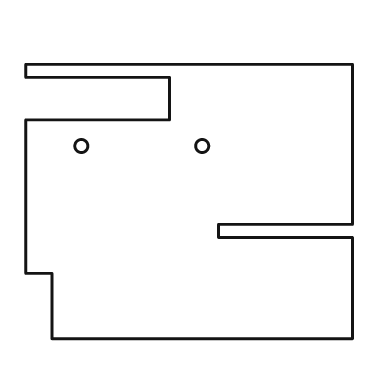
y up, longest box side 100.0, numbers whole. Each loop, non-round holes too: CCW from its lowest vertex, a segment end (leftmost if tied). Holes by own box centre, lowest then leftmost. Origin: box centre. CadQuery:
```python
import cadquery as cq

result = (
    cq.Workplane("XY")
    .moveTo(-42.0, -42.0)
    .lineTo(50.0, -42.0)
    .lineTo(50.0, -11.0)
    .lineTo(9.0, -11.0)
    .lineTo(9.0, -7.0)
    .lineTo(50.0, -7.0)
    .lineTo(50.0, 42.0)
    .lineTo(-50.0, 42.0)
    .lineTo(-50.0, 38.0)
    .lineTo(-6.0, 38.0)
    .lineTo(-6.0, 25.0)
    .lineTo(-50.0, 25.0)
    .lineTo(-50.0, -22.0)
    .lineTo(-42.0, -22.0)
    .close()
    .moveTo(-33.0, 17.0)
    .circle(2.0)
    .moveTo(4.0, 17.0)
    .circle(2.0)
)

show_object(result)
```